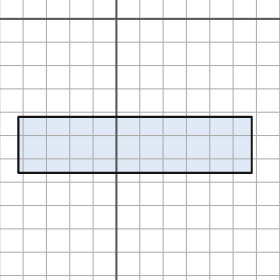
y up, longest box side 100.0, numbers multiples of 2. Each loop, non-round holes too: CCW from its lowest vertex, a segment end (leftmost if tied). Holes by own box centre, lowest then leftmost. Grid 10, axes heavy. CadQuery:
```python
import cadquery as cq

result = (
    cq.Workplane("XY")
    .moveTo(-42.0, -66.0)
    .lineTo(58.0, -66.0)
    .lineTo(58.0, -42.0)
    .lineTo(-42.0, -42.0)
    .close()
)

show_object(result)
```